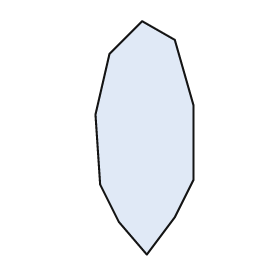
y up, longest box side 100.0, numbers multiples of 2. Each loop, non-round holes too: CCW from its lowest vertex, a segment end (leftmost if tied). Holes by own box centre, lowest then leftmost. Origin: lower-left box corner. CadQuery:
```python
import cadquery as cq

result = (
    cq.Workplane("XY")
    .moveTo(22.0, 0.0)
    .lineTo(34.0, 16.0)
    .lineTo(42.0, 32.0)
    .lineTo(42.0, 64.0)
    .lineTo(34.0, 92.0)
    .lineTo(20.0, 100.0)
    .lineTo(6.0, 86.0)
    .lineTo(0.0, 60.0)
    .lineTo(2.0, 30.0)
    .lineTo(10.0, 14.0)
    .close()
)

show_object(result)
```